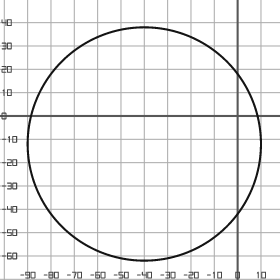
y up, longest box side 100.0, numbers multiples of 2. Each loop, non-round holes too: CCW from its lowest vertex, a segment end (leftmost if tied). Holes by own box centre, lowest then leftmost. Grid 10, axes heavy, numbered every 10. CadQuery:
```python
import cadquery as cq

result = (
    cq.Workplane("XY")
    .moveTo(-40.0, -12.0)
    .circle(50.0)
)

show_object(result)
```